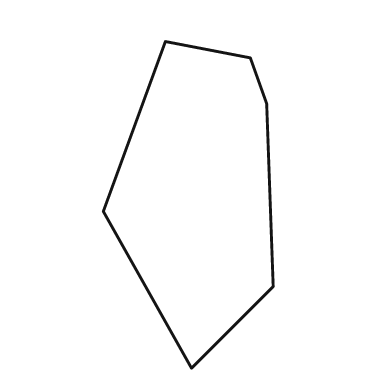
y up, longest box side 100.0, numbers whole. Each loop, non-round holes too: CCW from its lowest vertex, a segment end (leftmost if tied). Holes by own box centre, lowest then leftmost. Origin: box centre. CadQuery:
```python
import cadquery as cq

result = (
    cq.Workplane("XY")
    .moveTo(1.0, -50.0)
    .lineTo(26.0, -25.0)
    .lineTo(24.0, 31.0)
    .lineTo(19.0, 45.0)
    .lineTo(-7.0, 50.0)
    .lineTo(-26.0, -2.0)
    .close()
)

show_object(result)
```